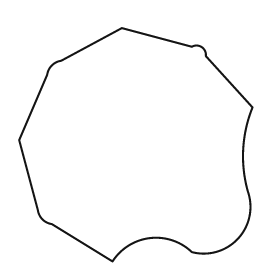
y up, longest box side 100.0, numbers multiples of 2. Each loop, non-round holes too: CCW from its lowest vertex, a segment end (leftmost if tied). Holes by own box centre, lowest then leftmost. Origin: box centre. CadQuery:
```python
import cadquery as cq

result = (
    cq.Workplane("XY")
    .moveTo(-10.0, -50.0)
    .threePointArc((6.0, -40.0), (24.0, -46.0))
    .threePointArc((44.0, -40.0), (48.0, -20.0))
    .threePointArc((46.0, -2.0), (50.0, 16.0))
    .lineTo(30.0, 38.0)
    .threePointArc((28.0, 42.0), (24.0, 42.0))
    .lineTo(-6.0, 50.0)
    .lineTo(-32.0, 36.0)
    .threePointArc((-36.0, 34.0), (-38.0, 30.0))
    .lineTo(-50.0, 2.0)
    .lineTo(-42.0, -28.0)
    .threePointArc((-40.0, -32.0), (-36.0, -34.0))
    .close()
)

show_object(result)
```